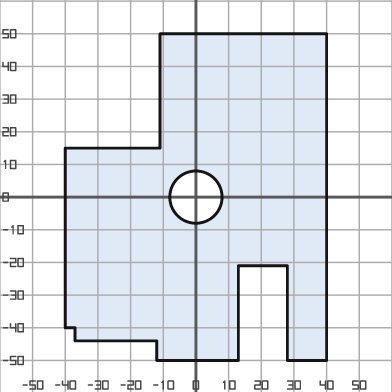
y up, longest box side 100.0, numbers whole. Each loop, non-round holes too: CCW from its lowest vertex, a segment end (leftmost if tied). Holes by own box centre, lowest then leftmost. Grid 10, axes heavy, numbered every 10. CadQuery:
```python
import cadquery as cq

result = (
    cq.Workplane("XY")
    .moveTo(-12.0, -50.0)
    .lineTo(13.0, -50.0)
    .lineTo(13.0, -21.0)
    .lineTo(28.0, -21.0)
    .lineTo(28.0, -50.0)
    .lineTo(40.0, -50.0)
    .lineTo(40.0, 50.0)
    .lineTo(-11.0, 50.0)
    .lineTo(-11.0, 15.0)
    .lineTo(-40.0, 15.0)
    .lineTo(-40.0, -40.0)
    .lineTo(-37.0, -40.0)
    .lineTo(-37.0, -44.0)
    .lineTo(-12.0, -44.0)
    .close()
    .moveTo(0.0, 0.0)
    .circle(8.0)
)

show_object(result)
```